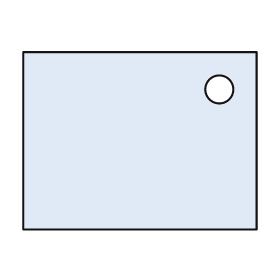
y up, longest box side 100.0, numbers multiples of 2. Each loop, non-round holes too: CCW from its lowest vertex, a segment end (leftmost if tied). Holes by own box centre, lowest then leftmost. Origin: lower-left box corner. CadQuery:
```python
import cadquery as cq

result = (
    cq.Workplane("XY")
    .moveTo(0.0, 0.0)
    .lineTo(100.0, 0.0)
    .lineTo(100.0, 76.0)
    .lineTo(0.0, 76.0)
    .close()
    .moveTo(84.0, 60.0)
    .circle(6.0)
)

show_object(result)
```